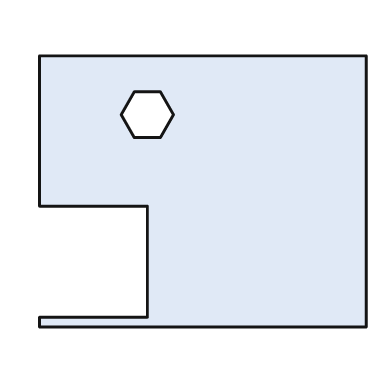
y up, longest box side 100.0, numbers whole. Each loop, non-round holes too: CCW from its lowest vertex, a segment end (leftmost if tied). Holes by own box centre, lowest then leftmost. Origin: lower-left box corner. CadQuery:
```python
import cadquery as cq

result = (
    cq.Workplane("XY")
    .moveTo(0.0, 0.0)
    .lineTo(100.0, 0.0)
    .lineTo(100.0, 83.0)
    .lineTo(0.0, 83.0)
    .lineTo(0.0, 37.0)
    .lineTo(33.0, 37.0)
    .lineTo(33.0, 3.0)
    .lineTo(0.0, 3.0)
    .close()
    .moveTo(29.0, 58.0)
    .lineTo(37.0, 58.0)
    .lineTo(41.0, 65.0)
    .lineTo(37.0, 72.0)
    .lineTo(29.0, 72.0)
    .lineTo(25.0, 65.0)
    .close()
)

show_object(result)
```